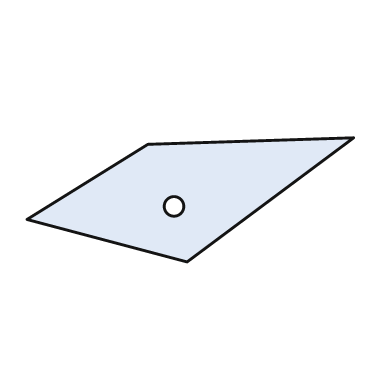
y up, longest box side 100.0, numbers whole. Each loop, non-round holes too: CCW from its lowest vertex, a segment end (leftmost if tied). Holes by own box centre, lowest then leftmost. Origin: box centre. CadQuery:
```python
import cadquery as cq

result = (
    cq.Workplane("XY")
    .moveTo(-1.0, -19.0)
    .lineTo(50.0, 19.0)
    .lineTo(-13.0, 17.0)
    .lineTo(-50.0, -6.0)
    .close()
    .moveTo(-5.0, -2.0)
    .circle(3.0)
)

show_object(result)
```